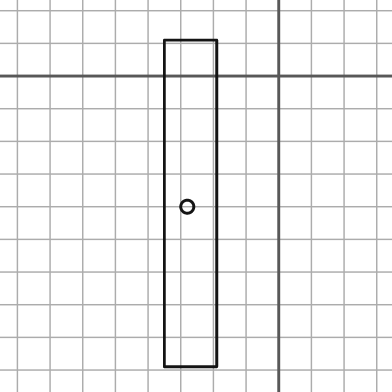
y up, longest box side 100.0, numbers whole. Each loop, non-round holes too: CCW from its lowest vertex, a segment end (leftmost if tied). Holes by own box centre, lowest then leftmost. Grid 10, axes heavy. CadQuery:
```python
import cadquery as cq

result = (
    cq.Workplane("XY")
    .moveTo(-35.0, -89.0)
    .lineTo(-19.0, -89.0)
    .lineTo(-19.0, 11.0)
    .lineTo(-35.0, 11.0)
    .close()
    .moveTo(-28.0, -40.0)
    .circle(2.0)
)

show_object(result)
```